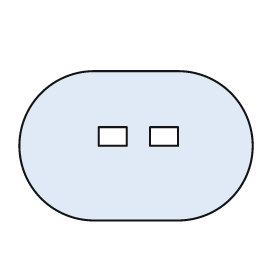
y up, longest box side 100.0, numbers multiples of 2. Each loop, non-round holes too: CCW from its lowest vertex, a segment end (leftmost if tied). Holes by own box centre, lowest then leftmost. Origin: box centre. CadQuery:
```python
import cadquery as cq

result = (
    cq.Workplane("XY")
    .moveTo(-18.0, -32.0)
    .lineTo(18.0, -32.0)
    .threePointArc((50.0, 0.0), (18.0, 32.0))
    .lineTo(-18.0, 32.0)
    .threePointArc((-50.0, 0.0), (-18.0, -32.0))
    .close()
    .moveTo(-16.0, 0.0)
    .lineTo(-4.0, 0.0)
    .lineTo(-4.0, 8.0)
    .lineTo(-16.0, 8.0)
    .close()
    .moveTo(6.0, 0.0)
    .lineTo(18.0, 0.0)
    .lineTo(18.0, 8.0)
    .lineTo(6.0, 8.0)
    .close()
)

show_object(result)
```